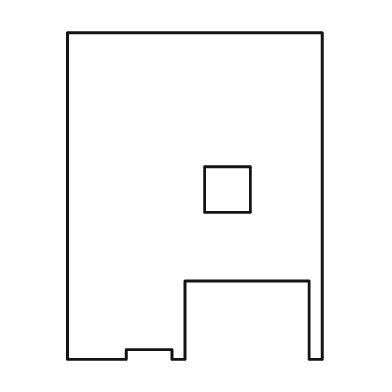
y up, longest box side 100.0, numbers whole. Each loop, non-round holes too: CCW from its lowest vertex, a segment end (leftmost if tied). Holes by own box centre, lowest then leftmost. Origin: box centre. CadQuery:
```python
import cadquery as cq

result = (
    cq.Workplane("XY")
    .moveTo(-39.0, -50.0)
    .lineTo(-21.0, -50.0)
    .lineTo(-21.0, -47.0)
    .lineTo(-7.0, -47.0)
    .lineTo(-7.0, -50.0)
    .lineTo(-3.0, -50.0)
    .lineTo(-3.0, -26.0)
    .lineTo(35.0, -26.0)
    .lineTo(35.0, -50.0)
    .lineTo(39.0, -50.0)
    .lineTo(39.0, 50.0)
    .lineTo(-39.0, 50.0)
    .close()
    .moveTo(3.0, -5.0)
    .lineTo(17.0, -5.0)
    .lineTo(17.0, 9.0)
    .lineTo(3.0, 9.0)
    .close()
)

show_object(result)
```